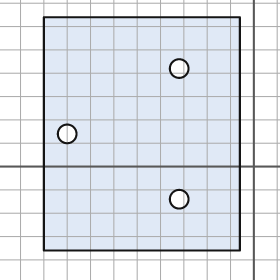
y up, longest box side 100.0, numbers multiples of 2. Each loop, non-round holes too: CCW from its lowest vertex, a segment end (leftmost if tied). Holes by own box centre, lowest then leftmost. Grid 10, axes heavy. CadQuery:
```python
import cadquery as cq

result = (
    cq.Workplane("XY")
    .moveTo(-90.0, -36.0)
    .lineTo(-6.0, -36.0)
    .lineTo(-6.0, 64.0)
    .lineTo(-90.0, 64.0)
    .close()
    .moveTo(-32.0, -14.0)
    .circle(4.0)
    .moveTo(-80.0, 14.0)
    .circle(4.0)
    .moveTo(-32.0, 42.0)
    .circle(4.0)
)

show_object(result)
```